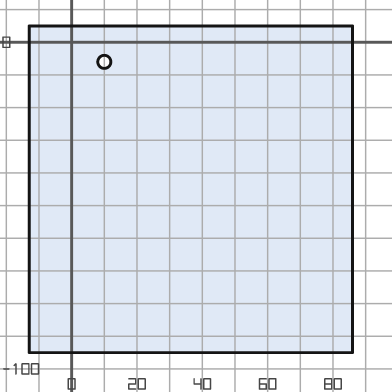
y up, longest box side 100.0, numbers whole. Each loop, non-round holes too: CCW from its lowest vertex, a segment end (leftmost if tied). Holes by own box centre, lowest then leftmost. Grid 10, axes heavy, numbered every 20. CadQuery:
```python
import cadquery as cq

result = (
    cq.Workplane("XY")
    .moveTo(-13.0, -95.0)
    .lineTo(86.0, -95.0)
    .lineTo(86.0, 5.0)
    .lineTo(-13.0, 5.0)
    .close()
    .moveTo(10.0, -6.0)
    .circle(2.0)
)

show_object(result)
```